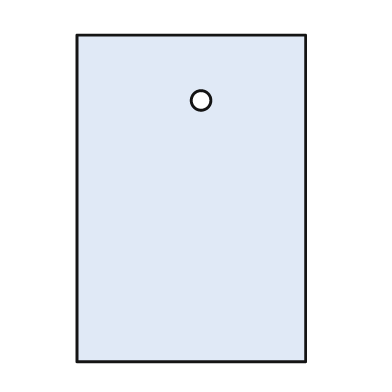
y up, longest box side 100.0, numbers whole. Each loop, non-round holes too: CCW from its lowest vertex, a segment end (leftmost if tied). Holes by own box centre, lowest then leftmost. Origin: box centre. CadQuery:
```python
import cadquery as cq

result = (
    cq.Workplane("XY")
    .moveTo(-35.0, -50.0)
    .lineTo(35.0, -50.0)
    .lineTo(35.0, 50.0)
    .lineTo(-35.0, 50.0)
    .close()
    .moveTo(3.0, 30.0)
    .circle(3.0)
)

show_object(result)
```